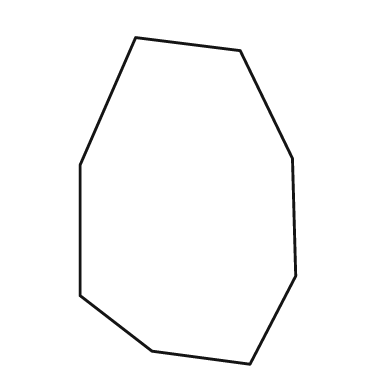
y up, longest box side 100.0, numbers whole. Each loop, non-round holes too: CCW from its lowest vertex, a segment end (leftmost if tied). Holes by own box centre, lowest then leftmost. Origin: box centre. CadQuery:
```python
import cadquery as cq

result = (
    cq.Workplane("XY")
    .moveTo(19.0, -50.0)
    .lineTo(33.0, -23.0)
    .lineTo(32.0, 13.0)
    .lineTo(16.0, 46.0)
    .lineTo(-16.0, 50.0)
    .lineTo(-33.0, 11.0)
    .lineTo(-33.0, -29.0)
    .lineTo(-11.0, -46.0)
    .close()
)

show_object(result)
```